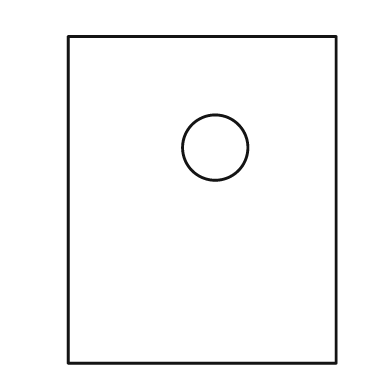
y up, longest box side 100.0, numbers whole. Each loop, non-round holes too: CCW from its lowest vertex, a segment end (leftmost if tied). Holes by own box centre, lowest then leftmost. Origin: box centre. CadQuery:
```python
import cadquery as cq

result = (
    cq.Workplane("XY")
    .moveTo(-41.0, -50.0)
    .lineTo(41.0, -50.0)
    .lineTo(41.0, 50.0)
    .lineTo(-41.0, 50.0)
    .close()
    .moveTo(4.0, 16.0)
    .circle(10.0)
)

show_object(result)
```